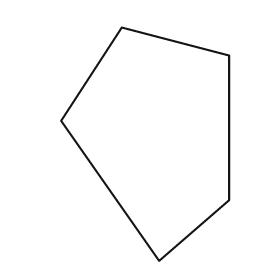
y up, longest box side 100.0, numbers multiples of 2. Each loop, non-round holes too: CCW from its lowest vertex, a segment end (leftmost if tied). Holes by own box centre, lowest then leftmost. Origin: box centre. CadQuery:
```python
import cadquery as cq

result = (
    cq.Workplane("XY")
    .moveTo(6.0, -50.0)
    .lineTo(36.0, -24.0)
    .lineTo(36.0, 38.0)
    .lineTo(-10.0, 50.0)
    .lineTo(-36.0, 10.0)
    .close()
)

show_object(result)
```